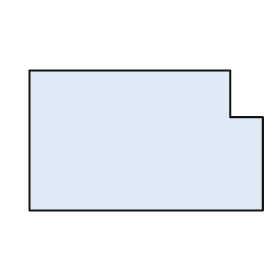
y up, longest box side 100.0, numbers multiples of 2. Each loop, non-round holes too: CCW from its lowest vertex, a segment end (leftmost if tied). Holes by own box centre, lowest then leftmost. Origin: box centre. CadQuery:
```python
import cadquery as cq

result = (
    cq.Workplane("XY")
    .moveTo(-50.0, -30.0)
    .lineTo(50.0, -30.0)
    .lineTo(50.0, 10.0)
    .lineTo(36.0, 10.0)
    .lineTo(36.0, 30.0)
    .lineTo(-50.0, 30.0)
    .close()
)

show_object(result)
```